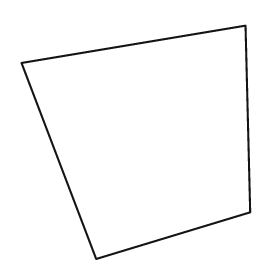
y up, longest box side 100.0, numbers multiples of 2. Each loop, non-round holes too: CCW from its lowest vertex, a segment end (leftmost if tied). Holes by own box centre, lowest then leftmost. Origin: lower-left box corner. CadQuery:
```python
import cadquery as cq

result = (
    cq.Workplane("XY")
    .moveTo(32.0, 0.0)
    .lineTo(98.0, 20.0)
    .lineTo(96.0, 100.0)
    .lineTo(0.0, 84.0)
    .close()
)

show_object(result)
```